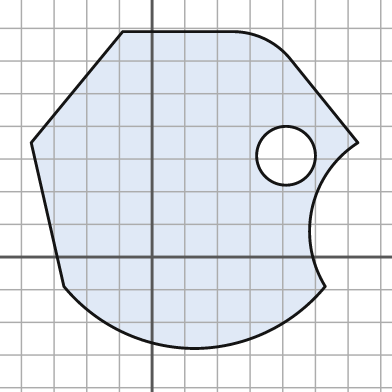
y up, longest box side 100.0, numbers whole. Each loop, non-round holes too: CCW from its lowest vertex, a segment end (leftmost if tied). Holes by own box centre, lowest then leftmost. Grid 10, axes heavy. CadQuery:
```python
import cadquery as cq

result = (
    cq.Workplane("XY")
    .moveTo(13.0, -28.0)
    .threePointArc((35.0, -23.0), (53.0, -9.0))
    .threePointArc((49.0, 15.0), (63.0, 35.0))
    .lineTo(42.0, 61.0)
    .threePointArc((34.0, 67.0), (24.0, 69.0))
    .lineTo(-9.0, 69.0)
    .lineTo(-37.0, 35.0)
    .lineTo(-27.0, -9.0)
    .threePointArc((-9.0, -23.0), (13.0, -28.0))
    .close()
    .moveTo(41.0, 31.0)
    .circle(9.0)
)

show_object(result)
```